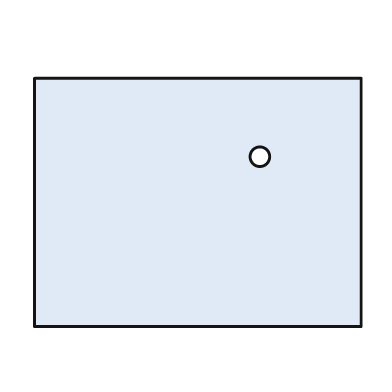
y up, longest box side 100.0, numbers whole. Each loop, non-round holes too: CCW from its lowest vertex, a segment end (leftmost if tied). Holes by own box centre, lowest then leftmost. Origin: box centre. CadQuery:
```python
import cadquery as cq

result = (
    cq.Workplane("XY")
    .moveTo(-50.0, -38.0)
    .lineTo(50.0, -38.0)
    .lineTo(50.0, 38.0)
    .lineTo(-50.0, 38.0)
    .close()
    .moveTo(19.0, 14.0)
    .circle(3.0)
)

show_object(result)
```